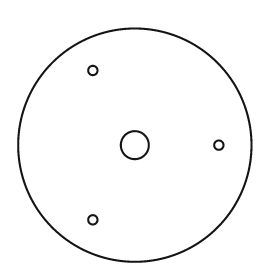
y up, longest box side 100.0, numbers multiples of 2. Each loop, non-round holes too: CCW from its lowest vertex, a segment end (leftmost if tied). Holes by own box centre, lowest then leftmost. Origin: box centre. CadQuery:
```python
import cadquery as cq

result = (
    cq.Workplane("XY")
    .moveTo(0.0, 0.0)
    .circle(50.0)
    .moveTo(-18.0, -32.0)
    .circle(2.0)
    .moveTo(0.0, 0.0)
    .circle(6.0)
    .moveTo(36.0, 0.0)
    .circle(2.0)
    .moveTo(-18.0, 32.0)
    .circle(2.0)
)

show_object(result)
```